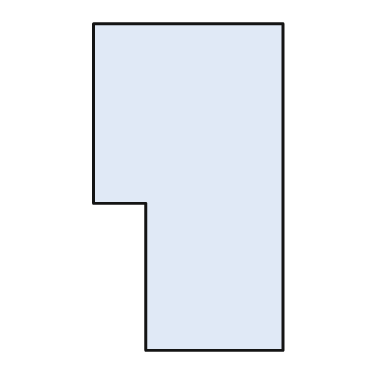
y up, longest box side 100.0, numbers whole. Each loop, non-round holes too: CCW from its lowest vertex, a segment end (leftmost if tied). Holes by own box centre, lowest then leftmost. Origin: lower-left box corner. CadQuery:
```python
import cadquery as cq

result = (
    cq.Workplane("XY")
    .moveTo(16.0, 0.0)
    .lineTo(58.0, 0.0)
    .lineTo(58.0, 100.0)
    .lineTo(0.0, 100.0)
    .lineTo(0.0, 45.0)
    .lineTo(16.0, 45.0)
    .close()
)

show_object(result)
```